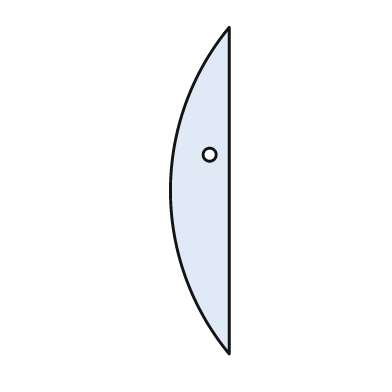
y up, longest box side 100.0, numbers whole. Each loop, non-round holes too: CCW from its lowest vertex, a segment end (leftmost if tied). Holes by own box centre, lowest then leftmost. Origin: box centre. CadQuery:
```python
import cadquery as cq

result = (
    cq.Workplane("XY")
    .moveTo(9.0, -50.0)
    .lineTo(9.0, 50.0)
    .threePointArc((-9.0, 0.0), (9.0, -50.0))
    .close()
    .moveTo(3.0, 11.0)
    .circle(2.0)
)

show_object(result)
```